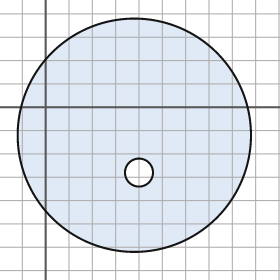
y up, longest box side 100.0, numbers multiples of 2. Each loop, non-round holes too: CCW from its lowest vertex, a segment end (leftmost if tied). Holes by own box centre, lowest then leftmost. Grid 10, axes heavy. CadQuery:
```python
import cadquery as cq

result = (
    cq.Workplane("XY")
    .moveTo(38.0, -12.0)
    .circle(50.0)
    .moveTo(40.0, -28.0)
    .circle(6.0)
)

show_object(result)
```